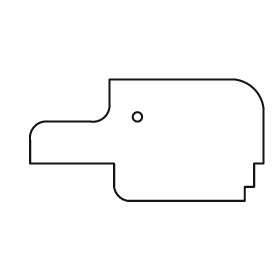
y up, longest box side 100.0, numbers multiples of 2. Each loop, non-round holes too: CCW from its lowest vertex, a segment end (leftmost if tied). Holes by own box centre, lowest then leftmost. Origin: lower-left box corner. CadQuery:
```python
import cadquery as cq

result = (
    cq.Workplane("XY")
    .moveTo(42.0, 0.0)
    .lineTo(92.0, 0.0)
    .lineTo(92.0, 6.0)
    .lineTo(96.0, 6.0)
    .lineTo(96.0, 16.0)
    .lineTo(100.0, 16.0)
    .lineTo(100.0, 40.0)
    .threePointArc((96.0, 48.0), (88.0, 52.0))
    .lineTo(34.0, 52.0)
    .lineTo(34.0, 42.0)
    .threePointArc((32.0, 36.0), (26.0, 34.0))
    .lineTo(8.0, 34.0)
    .threePointArc((2.0, 32.0), (0.0, 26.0))
    .lineTo(0.0, 16.0)
    .lineTo(36.0, 16.0)
    .lineTo(36.0, 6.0)
    .threePointArc((38.0, 2.0), (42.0, 0.0))
    .close()
    .moveTo(46.0, 36.0)
    .circle(2.0)
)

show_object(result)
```